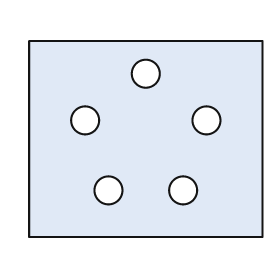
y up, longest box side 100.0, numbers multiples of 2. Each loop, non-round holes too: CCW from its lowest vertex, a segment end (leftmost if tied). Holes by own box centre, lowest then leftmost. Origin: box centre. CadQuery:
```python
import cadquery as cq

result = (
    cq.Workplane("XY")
    .moveTo(-50.0, -42.0)
    .lineTo(50.0, -42.0)
    .lineTo(50.0, 42.0)
    .lineTo(-50.0, 42.0)
    .close()
    .moveTo(-16.0, -22.0)
    .circle(6.0)
    .moveTo(16.0, -22.0)
    .circle(6.0)
    .moveTo(-26.0, 8.0)
    .circle(6.0)
    .moveTo(26.0, 8.0)
    .circle(6.0)
    .moveTo(0.0, 28.0)
    .circle(6.0)
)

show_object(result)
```